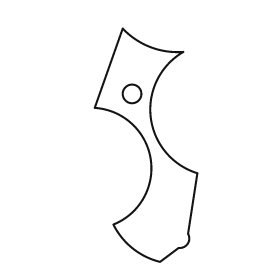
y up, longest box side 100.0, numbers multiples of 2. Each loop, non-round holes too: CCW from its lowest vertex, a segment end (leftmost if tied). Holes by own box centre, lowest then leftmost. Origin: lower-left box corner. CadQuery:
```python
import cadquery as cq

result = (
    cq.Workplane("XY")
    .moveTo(28.0, 0.0)
    .lineTo(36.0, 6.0)
    .threePointArc((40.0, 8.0), (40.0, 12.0))
    .lineTo(44.0, 38.0)
    .threePointArc((24.0, 62.0), (38.0, 90.0))
    .threePointArc((24.0, 92.0), (12.0, 100.0))
    .lineTo(0.0, 66.0)
    .threePointArc((24.0, 44.0), (8.0, 16.0))
    .threePointArc((16.0, 6.0), (28.0, 0.0))
    .close()
    .moveTo(16.0, 72.0)
    .circle(4.0)
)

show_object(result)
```